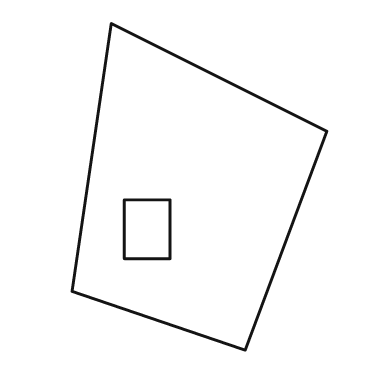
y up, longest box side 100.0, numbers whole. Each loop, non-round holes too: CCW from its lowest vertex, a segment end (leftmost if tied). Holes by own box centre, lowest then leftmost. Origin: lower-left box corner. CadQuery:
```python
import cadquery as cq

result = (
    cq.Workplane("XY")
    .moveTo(53.0, 0.0)
    .lineTo(78.0, 67.0)
    .lineTo(12.0, 100.0)
    .lineTo(0.0, 18.0)
    .close()
    .moveTo(16.0, 28.0)
    .lineTo(30.0, 28.0)
    .lineTo(30.0, 46.0)
    .lineTo(16.0, 46.0)
    .close()
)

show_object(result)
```